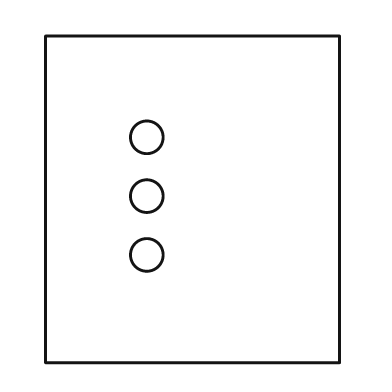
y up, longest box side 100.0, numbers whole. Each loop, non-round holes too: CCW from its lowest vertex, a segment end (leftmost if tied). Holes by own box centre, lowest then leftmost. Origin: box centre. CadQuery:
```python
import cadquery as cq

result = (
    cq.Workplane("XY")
    .moveTo(-45.0, -50.0)
    .lineTo(45.0, -50.0)
    .lineTo(45.0, 50.0)
    .lineTo(-45.0, 50.0)
    .close()
    .moveTo(-14.0, -17.0)
    .circle(5.0)
    .moveTo(-14.0, 1.0)
    .circle(5.0)
    .moveTo(-14.0, 19.0)
    .circle(5.0)
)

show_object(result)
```